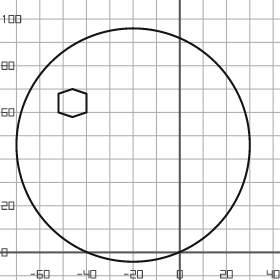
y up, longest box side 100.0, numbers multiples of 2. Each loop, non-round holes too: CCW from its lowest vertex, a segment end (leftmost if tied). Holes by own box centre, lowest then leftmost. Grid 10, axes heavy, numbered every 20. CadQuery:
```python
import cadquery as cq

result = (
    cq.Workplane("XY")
    .moveTo(-20.0, 46.0)
    .circle(50.0)
    .moveTo(-46.0, 58.0)
    .lineTo(-40.0, 60.0)
    .lineTo(-40.0, 68.0)
    .lineTo(-46.0, 70.0)
    .lineTo(-52.0, 68.0)
    .lineTo(-52.0, 60.0)
    .close()
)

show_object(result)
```